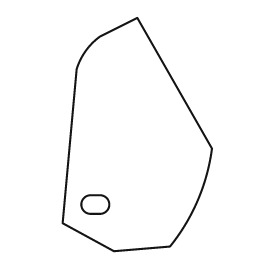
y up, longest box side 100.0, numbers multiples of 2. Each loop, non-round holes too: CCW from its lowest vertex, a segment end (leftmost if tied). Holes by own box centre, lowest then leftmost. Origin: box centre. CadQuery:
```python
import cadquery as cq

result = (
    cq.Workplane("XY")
    .moveTo(-10.0, -50.0)
    .lineTo(14.0, -48.0)
    .threePointArc((26.0, -28.0), (32.0, -6.0))
    .lineTo(0.0, 50.0)
    .lineTo(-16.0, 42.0)
    .threePointArc((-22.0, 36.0), (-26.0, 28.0))
    .lineTo(-32.0, -38.0)
    .close()
    .moveTo(-20.0, -34.0)
    .lineTo(-16.0, -34.0)
    .threePointArc((-12.0, -30.0), (-16.0, -26.0))
    .lineTo(-20.0, -26.0)
    .threePointArc((-24.0, -30.0), (-20.0, -34.0))
    .close()
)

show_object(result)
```